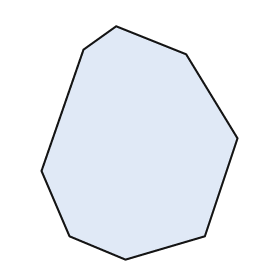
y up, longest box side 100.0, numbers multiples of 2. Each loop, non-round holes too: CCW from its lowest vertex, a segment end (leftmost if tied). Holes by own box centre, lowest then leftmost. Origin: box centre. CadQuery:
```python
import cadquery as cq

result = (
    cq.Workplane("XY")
    .moveTo(-6.0, -50.0)
    .lineTo(28.0, -40.0)
    .lineTo(42.0, 2.0)
    .lineTo(20.0, 38.0)
    .lineTo(-10.0, 50.0)
    .lineTo(-24.0, 40.0)
    .lineTo(-42.0, -12.0)
    .lineTo(-30.0, -40.0)
    .close()
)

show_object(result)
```